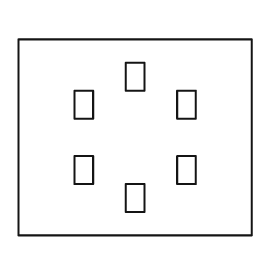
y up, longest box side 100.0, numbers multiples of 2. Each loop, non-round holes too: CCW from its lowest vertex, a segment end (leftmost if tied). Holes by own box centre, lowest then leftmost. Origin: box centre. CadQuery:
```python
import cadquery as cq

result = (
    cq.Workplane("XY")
    .moveTo(-50.0, -42.0)
    .lineTo(50.0, -42.0)
    .lineTo(50.0, 42.0)
    .lineTo(-50.0, 42.0)
    .close()
    .moveTo(-4.0, -32.0)
    .lineTo(4.0, -32.0)
    .lineTo(4.0, -20.0)
    .lineTo(-4.0, -20.0)
    .close()
    .moveTo(-26.0, -20.0)
    .lineTo(-18.0, -20.0)
    .lineTo(-18.0, -8.0)
    .lineTo(-26.0, -8.0)
    .close()
    .moveTo(18.0, -20.0)
    .lineTo(26.0, -20.0)
    .lineTo(26.0, -8.0)
    .lineTo(18.0, -8.0)
    .close()
    .moveTo(-26.0, 8.0)
    .lineTo(-18.0, 8.0)
    .lineTo(-18.0, 20.0)
    .lineTo(-26.0, 20.0)
    .close()
    .moveTo(18.0, 8.0)
    .lineTo(26.0, 8.0)
    .lineTo(26.0, 20.0)
    .lineTo(18.0, 20.0)
    .close()
    .moveTo(-4.0, 20.0)
    .lineTo(4.0, 20.0)
    .lineTo(4.0, 32.0)
    .lineTo(-4.0, 32.0)
    .close()
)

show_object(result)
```